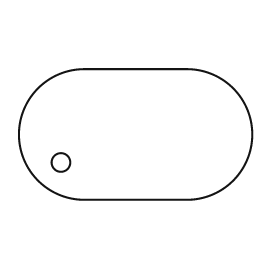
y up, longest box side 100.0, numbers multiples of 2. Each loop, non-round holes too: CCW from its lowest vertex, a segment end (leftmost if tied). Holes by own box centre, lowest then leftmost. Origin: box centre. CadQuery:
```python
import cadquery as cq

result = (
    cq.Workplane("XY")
    .moveTo(-22.0, -28.0)
    .lineTo(22.0, -28.0)
    .threePointArc((50.0, 0.0), (22.0, 28.0))
    .lineTo(-22.0, 28.0)
    .threePointArc((-50.0, 0.0), (-22.0, -28.0))
    .close()
    .moveTo(-32.0, -12.0)
    .circle(4.0)
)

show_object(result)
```